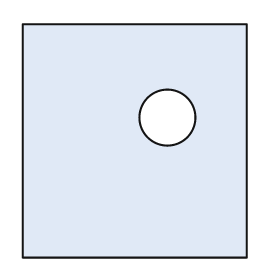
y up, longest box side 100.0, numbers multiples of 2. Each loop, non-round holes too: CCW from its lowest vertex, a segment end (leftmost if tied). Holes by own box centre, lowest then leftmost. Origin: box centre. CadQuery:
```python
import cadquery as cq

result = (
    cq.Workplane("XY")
    .moveTo(-48.0, -50.0)
    .lineTo(48.0, -50.0)
    .lineTo(48.0, 50.0)
    .lineTo(-48.0, 50.0)
    .close()
    .moveTo(14.0, 10.0)
    .circle(12.0)
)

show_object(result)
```